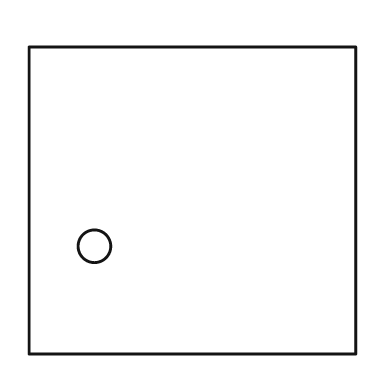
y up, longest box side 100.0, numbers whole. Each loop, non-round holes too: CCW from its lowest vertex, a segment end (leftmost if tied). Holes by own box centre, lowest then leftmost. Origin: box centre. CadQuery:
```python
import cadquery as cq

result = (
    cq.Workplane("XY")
    .moveTo(-50.0, -47.0)
    .lineTo(50.0, -47.0)
    .lineTo(50.0, 47.0)
    .lineTo(-50.0, 47.0)
    .close()
    .moveTo(-30.0, -14.0)
    .circle(5.0)
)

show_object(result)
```